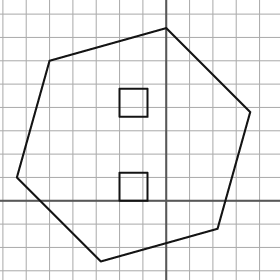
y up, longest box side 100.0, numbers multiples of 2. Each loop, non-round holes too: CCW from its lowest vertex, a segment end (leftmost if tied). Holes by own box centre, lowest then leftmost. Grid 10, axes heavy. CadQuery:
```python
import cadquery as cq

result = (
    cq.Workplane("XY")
    .moveTo(-28.0, -26.0)
    .lineTo(22.0, -12.0)
    .lineTo(36.0, 38.0)
    .lineTo(0.0, 74.0)
    .lineTo(-50.0, 60.0)
    .lineTo(-64.0, 10.0)
    .close()
    .moveTo(-20.0, 0.0)
    .lineTo(-8.0, 0.0)
    .lineTo(-8.0, 12.0)
    .lineTo(-20.0, 12.0)
    .close()
    .moveTo(-20.0, 36.0)
    .lineTo(-8.0, 36.0)
    .lineTo(-8.0, 48.0)
    .lineTo(-20.0, 48.0)
    .close()
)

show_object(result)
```